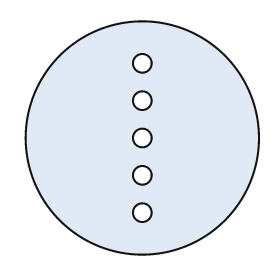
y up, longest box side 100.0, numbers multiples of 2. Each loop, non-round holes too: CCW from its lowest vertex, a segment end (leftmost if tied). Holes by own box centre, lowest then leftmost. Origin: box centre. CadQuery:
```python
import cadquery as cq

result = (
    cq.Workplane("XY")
    .moveTo(0.0, 0.0)
    .circle(50.0)
    .moveTo(0.0, -32.0)
    .circle(4.0)
    .moveTo(0.0, -16.0)
    .circle(4.0)
    .moveTo(0.0, 0.0)
    .circle(4.0)
    .moveTo(0.0, 16.0)
    .circle(4.0)
    .moveTo(0.0, 32.0)
    .circle(4.0)
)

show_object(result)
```